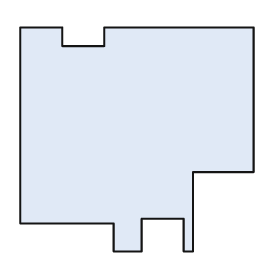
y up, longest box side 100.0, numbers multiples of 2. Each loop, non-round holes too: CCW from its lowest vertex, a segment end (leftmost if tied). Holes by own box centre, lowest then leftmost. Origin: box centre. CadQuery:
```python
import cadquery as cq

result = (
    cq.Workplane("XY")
    .moveTo(-10.0, -48.0)
    .lineTo(2.0, -48.0)
    .lineTo(2.0, -34.0)
    .lineTo(20.0, -34.0)
    .lineTo(20.0, -48.0)
    .lineTo(24.0, -48.0)
    .lineTo(24.0, -14.0)
    .lineTo(50.0, -14.0)
    .lineTo(50.0, 48.0)
    .lineTo(-14.0, 48.0)
    .lineTo(-14.0, 40.0)
    .lineTo(-32.0, 40.0)
    .lineTo(-32.0, 48.0)
    .lineTo(-50.0, 48.0)
    .lineTo(-50.0, -36.0)
    .lineTo(-10.0, -36.0)
    .close()
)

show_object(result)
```